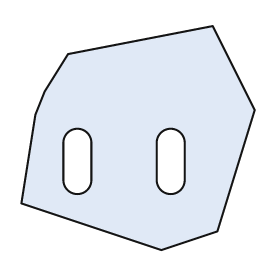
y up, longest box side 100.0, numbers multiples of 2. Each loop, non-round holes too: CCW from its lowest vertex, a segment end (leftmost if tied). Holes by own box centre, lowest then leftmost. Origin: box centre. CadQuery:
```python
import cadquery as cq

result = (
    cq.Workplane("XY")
    .moveTo(10.0, -48.0)
    .lineTo(34.0, -40.0)
    .lineTo(50.0, 12.0)
    .lineTo(32.0, 48.0)
    .lineTo(-30.0, 36.0)
    .lineTo(-40.0, 20.0)
    .lineTo(-44.0, 10.0)
    .lineTo(-50.0, -28.0)
    .close()
    .moveTo(-32.0, -18.0)
    .threePointArc((-26.0, -24.0), (-20.0, -18.0))
    .lineTo(-20.0, -2.0)
    .threePointArc((-26.0, 4.0), (-32.0, -2.0))
    .close()
    .moveTo(8.0, -18.0)
    .threePointArc((14.0, -24.0), (20.0, -18.0))
    .lineTo(20.0, -2.0)
    .threePointArc((14.0, 4.0), (8.0, -2.0))
    .close()
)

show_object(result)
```